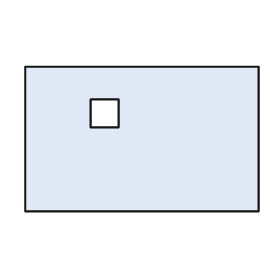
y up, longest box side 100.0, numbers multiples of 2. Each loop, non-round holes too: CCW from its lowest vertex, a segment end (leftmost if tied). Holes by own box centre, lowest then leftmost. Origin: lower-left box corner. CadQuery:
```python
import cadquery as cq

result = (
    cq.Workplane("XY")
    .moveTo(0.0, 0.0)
    .lineTo(100.0, 0.0)
    .lineTo(100.0, 62.0)
    .lineTo(0.0, 62.0)
    .close()
    .moveTo(28.0, 36.0)
    .lineTo(40.0, 36.0)
    .lineTo(40.0, 48.0)
    .lineTo(28.0, 48.0)
    .close()
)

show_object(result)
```